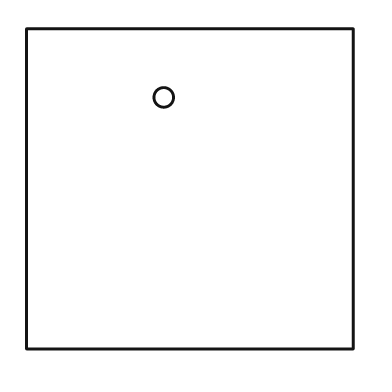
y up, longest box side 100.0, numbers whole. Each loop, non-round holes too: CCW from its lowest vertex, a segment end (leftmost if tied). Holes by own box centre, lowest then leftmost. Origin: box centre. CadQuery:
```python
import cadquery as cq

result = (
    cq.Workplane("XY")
    .moveTo(-50.0, -49.0)
    .lineTo(50.0, -49.0)
    .lineTo(50.0, 49.0)
    .lineTo(-50.0, 49.0)
    .close()
    .moveTo(-8.0, 28.0)
    .circle(3.0)
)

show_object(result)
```